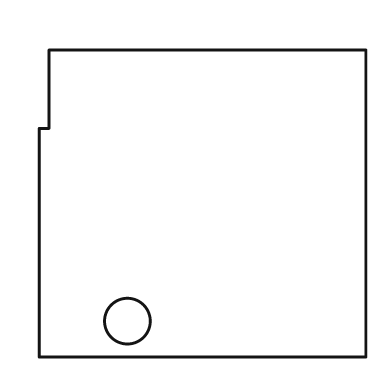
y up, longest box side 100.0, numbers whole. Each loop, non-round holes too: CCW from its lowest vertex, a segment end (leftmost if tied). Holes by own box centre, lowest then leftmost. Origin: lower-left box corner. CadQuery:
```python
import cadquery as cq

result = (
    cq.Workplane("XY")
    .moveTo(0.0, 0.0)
    .lineTo(100.0, 0.0)
    .lineTo(100.0, 94.0)
    .lineTo(3.0, 94.0)
    .lineTo(3.0, 70.0)
    .lineTo(0.0, 70.0)
    .close()
    .moveTo(27.0, 11.0)
    .circle(7.0)
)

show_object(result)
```